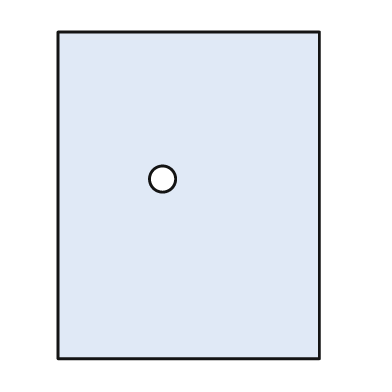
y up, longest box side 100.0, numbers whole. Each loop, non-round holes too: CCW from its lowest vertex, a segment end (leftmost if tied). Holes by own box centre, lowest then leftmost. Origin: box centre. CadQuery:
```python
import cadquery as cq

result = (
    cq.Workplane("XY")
    .moveTo(-40.0, -50.0)
    .lineTo(40.0, -50.0)
    .lineTo(40.0, 50.0)
    .lineTo(-40.0, 50.0)
    .close()
    .moveTo(-8.0, 5.0)
    .circle(4.0)
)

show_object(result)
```